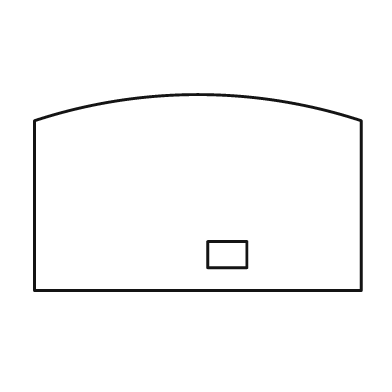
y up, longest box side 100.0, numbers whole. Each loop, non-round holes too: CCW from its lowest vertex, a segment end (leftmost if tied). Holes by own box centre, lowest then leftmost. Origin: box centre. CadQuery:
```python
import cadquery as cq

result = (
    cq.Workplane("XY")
    .moveTo(-50.0, -30.0)
    .lineTo(50.0, -30.0)
    .lineTo(50.0, 22.0)
    .threePointArc((0.0, 30.0), (-50.0, 22.0))
    .close()
    .moveTo(3.0, -23.0)
    .lineTo(15.0, -23.0)
    .lineTo(15.0, -15.0)
    .lineTo(3.0, -15.0)
    .close()
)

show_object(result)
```